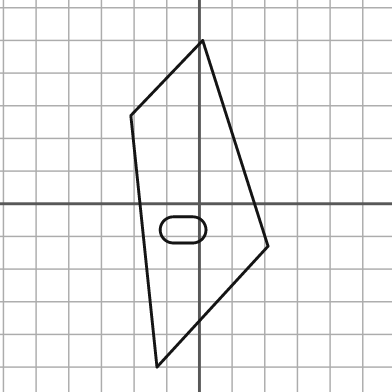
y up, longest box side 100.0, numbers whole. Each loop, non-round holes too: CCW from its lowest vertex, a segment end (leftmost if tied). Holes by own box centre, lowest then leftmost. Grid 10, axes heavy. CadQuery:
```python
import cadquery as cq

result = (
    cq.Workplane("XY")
    .moveTo(-13.0, -50.0)
    .lineTo(21.0, -13.0)
    .lineTo(1.0, 50.0)
    .lineTo(-21.0, 27.0)
    .close()
    .moveTo(-8.0, -12.0)
    .lineTo(-2.0, -12.0)
    .threePointArc((2.0, -8.0), (-2.0, -4.0))
    .lineTo(-8.0, -4.0)
    .threePointArc((-12.0, -8.0), (-8.0, -12.0))
    .close()
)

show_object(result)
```